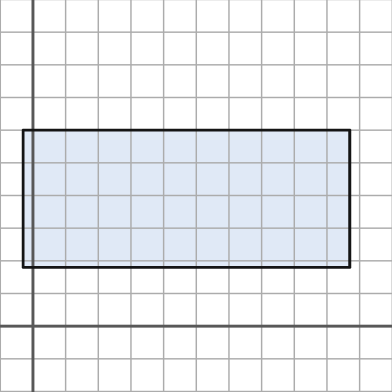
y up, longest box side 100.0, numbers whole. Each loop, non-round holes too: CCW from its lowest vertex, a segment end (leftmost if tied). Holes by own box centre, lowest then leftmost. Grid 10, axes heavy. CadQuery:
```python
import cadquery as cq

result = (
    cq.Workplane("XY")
    .moveTo(-3.0, 18.0)
    .lineTo(97.0, 18.0)
    .lineTo(97.0, 60.0)
    .lineTo(-3.0, 60.0)
    .close()
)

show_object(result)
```